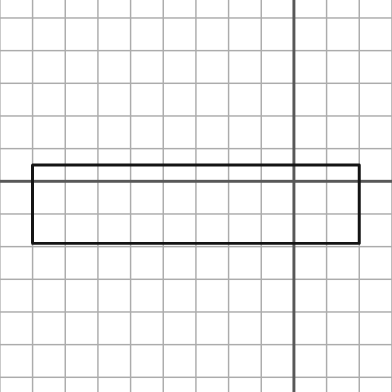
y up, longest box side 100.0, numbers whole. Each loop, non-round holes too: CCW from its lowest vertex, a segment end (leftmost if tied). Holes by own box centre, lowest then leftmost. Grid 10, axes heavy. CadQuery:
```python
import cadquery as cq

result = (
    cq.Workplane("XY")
    .moveTo(-80.0, -19.0)
    .lineTo(20.0, -19.0)
    .lineTo(20.0, 5.0)
    .lineTo(-80.0, 5.0)
    .close()
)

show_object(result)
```